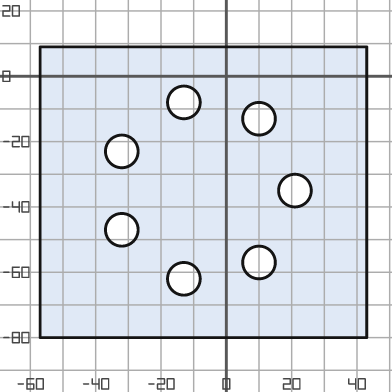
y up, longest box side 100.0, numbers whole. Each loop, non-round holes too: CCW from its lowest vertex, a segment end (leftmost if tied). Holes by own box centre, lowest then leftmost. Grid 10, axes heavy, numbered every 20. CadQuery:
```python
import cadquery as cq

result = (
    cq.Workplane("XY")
    .moveTo(-57.0, -80.0)
    .lineTo(43.0, -80.0)
    .lineTo(43.0, 9.0)
    .lineTo(-57.0, 9.0)
    .close()
    .moveTo(-13.0, -62.0)
    .circle(5.0)
    .moveTo(10.0, -57.0)
    .circle(5.0)
    .moveTo(-32.0, -47.0)
    .circle(5.0)
    .moveTo(21.0, -35.0)
    .circle(5.0)
    .moveTo(-32.0, -23.0)
    .circle(5.0)
    .moveTo(10.0, -13.0)
    .circle(5.0)
    .moveTo(-13.0, -8.0)
    .circle(5.0)
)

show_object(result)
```